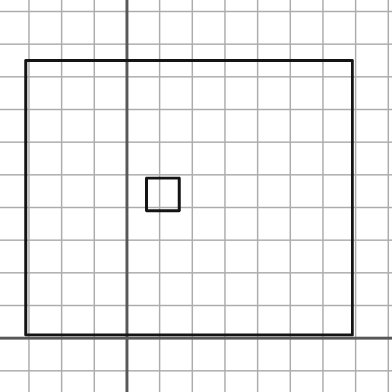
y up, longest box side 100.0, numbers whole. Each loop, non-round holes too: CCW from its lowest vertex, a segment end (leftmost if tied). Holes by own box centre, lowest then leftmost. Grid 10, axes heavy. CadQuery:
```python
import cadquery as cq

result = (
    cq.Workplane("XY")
    .moveTo(-31.0, 1.0)
    .lineTo(69.0, 1.0)
    .lineTo(69.0, 85.0)
    .lineTo(-31.0, 85.0)
    .close()
    .moveTo(6.0, 39.0)
    .lineTo(16.0, 39.0)
    .lineTo(16.0, 49.0)
    .lineTo(6.0, 49.0)
    .close()
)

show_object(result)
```